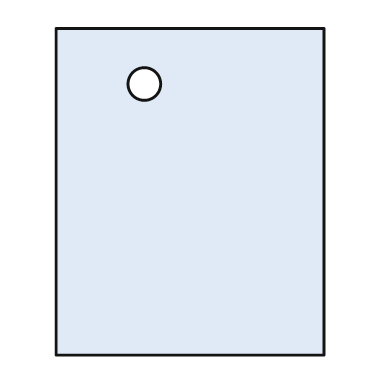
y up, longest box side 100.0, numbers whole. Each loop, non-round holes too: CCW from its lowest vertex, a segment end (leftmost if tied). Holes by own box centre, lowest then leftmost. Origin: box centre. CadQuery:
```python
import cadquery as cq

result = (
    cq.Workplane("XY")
    .moveTo(-41.0, -50.0)
    .lineTo(41.0, -50.0)
    .lineTo(41.0, 50.0)
    .lineTo(-41.0, 50.0)
    .close()
    .moveTo(-14.0, 33.0)
    .circle(5.0)
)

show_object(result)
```